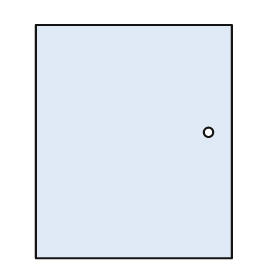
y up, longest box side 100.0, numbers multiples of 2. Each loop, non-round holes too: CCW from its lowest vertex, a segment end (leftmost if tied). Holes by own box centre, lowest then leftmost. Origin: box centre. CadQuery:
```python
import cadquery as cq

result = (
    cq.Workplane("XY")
    .moveTo(-42.0, -50.0)
    .lineTo(42.0, -50.0)
    .lineTo(42.0, 50.0)
    .lineTo(-42.0, 50.0)
    .close()
    .moveTo(32.0, 4.0)
    .circle(2.0)
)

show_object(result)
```